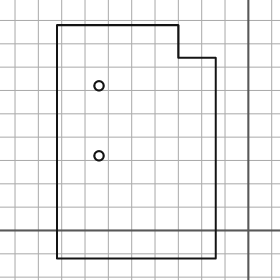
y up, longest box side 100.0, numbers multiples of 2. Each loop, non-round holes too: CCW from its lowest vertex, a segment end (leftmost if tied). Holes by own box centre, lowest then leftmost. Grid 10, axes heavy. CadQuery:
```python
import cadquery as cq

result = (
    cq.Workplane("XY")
    .moveTo(-82.0, -12.0)
    .lineTo(-14.0, -12.0)
    .lineTo(-14.0, 74.0)
    .lineTo(-30.0, 74.0)
    .lineTo(-30.0, 88.0)
    .lineTo(-82.0, 88.0)
    .close()
    .moveTo(-64.0, 32.0)
    .circle(2.0)
    .moveTo(-64.0, 62.0)
    .circle(2.0)
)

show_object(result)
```